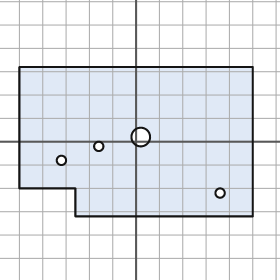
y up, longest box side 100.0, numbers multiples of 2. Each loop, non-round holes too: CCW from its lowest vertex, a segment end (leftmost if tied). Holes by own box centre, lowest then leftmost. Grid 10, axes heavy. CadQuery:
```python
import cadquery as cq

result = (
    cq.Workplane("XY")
    .moveTo(-26.0, -32.0)
    .lineTo(50.0, -32.0)
    .lineTo(50.0, 32.0)
    .lineTo(-50.0, 32.0)
    .lineTo(-50.0, -20.0)
    .lineTo(-26.0, -20.0)
    .close()
    .moveTo(36.0, -22.0)
    .circle(2.0)
    .moveTo(-32.0, -8.0)
    .circle(2.0)
    .moveTo(-16.0, -2.0)
    .circle(2.0)
    .moveTo(2.0, 2.0)
    .circle(4.0)
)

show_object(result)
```